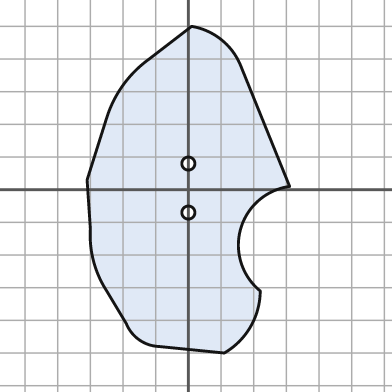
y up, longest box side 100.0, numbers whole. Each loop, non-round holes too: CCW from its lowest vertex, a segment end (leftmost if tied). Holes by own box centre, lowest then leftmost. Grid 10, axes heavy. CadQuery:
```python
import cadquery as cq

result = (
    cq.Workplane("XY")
    .moveTo(11.0, -50.0)
    .threePointArc((19.0, -42.0), (22.0, -31.0))
    .threePointArc((16.0, -12.0), (31.0, 1.0))
    .lineTo(16.0, 38.0)
    .threePointArc((10.0, 46.0), (1.0, 50.0))
    .lineTo(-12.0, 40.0)
    .threePointArc((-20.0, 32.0), (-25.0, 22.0))
    .lineTo(-31.0, 3.0)
    .lineTo(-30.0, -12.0)
    .threePointArc((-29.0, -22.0), (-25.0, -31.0))
    .lineTo(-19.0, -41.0)
    .threePointArc((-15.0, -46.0), (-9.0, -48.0))
    .close()
    .moveTo(0.0, -7.0)
    .circle(2.0)
    .moveTo(0.0, 8.0)
    .circle(2.0)
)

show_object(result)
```